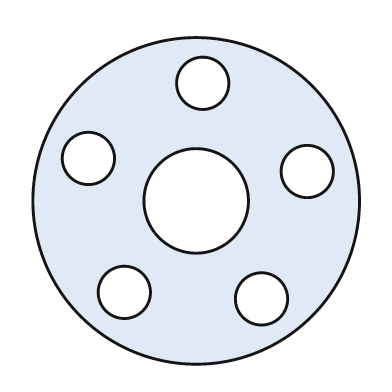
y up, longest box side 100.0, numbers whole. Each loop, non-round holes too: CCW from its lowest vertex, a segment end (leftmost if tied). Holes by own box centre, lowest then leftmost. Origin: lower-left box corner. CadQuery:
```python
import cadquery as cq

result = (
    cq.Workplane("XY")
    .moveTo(50.0, 50.0)
    .circle(50.0)
    .moveTo(70.0, 20.0)
    .circle(8.0)
    .moveTo(28.0, 22.0)
    .circle(8.0)
    .moveTo(50.0, 50.0)
    .circle(16.0)
    .moveTo(84.0, 59.0)
    .circle(8.0)
    .moveTo(17.0, 63.0)
    .circle(8.0)
    .moveTo(52.0, 86.0)
    .circle(8.0)
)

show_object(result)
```